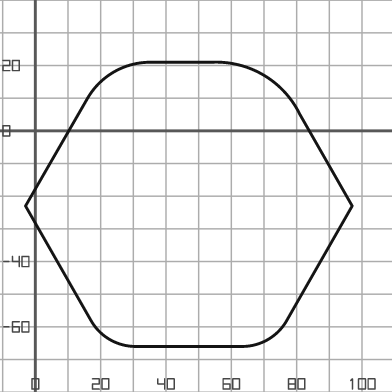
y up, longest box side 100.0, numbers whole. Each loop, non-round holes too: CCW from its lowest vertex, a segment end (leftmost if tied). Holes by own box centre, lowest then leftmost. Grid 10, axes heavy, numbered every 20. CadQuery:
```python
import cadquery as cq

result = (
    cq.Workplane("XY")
    .moveTo(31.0, -66.0)
    .lineTo(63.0, -66.0)
    .threePointArc((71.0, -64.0), (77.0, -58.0))
    .lineTo(97.0, -23.0)
    .lineTo(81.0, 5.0)
    .threePointArc((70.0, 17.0), (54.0, 21.0))
    .lineTo(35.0, 21.0)
    .threePointArc((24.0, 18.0), (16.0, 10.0))
    .lineTo(-3.0, -23.0)
    .lineTo(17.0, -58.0)
    .threePointArc((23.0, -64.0), (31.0, -66.0))
    .close()
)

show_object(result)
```